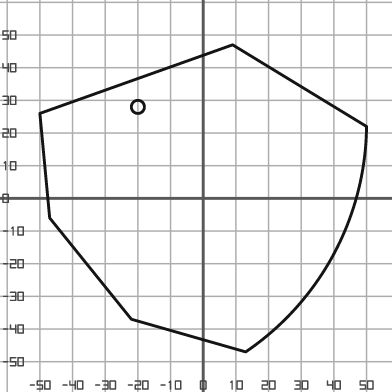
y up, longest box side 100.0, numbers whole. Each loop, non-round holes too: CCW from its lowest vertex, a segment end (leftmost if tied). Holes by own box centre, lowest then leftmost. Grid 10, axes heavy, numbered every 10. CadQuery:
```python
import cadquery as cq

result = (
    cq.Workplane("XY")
    .moveTo(13.0, -47.0)
    .threePointArc((40.0, -17.0), (50.0, 22.0))
    .lineTo(9.0, 47.0)
    .lineTo(-50.0, 26.0)
    .lineTo(-47.0, -6.0)
    .lineTo(-22.0, -37.0)
    .close()
    .moveTo(-20.0, 28.0)
    .circle(2.0)
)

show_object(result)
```